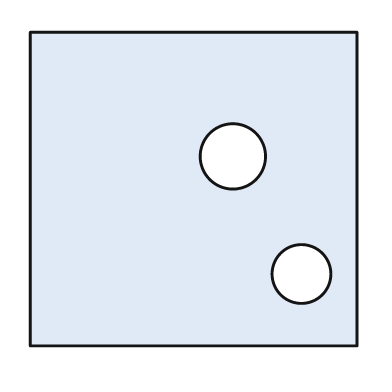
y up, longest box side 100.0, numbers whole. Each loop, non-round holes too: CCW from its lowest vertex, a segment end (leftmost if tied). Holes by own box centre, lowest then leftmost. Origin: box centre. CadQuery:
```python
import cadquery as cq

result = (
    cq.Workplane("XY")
    .moveTo(-50.0, -48.0)
    .lineTo(50.0, -48.0)
    .lineTo(50.0, 48.0)
    .lineTo(-50.0, 48.0)
    .close()
    .moveTo(33.0, -26.0)
    .circle(9.0)
    .moveTo(12.0, 10.0)
    .circle(10.0)
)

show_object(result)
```